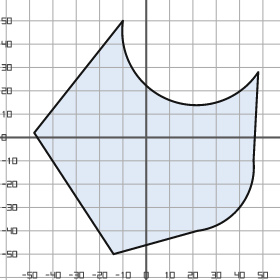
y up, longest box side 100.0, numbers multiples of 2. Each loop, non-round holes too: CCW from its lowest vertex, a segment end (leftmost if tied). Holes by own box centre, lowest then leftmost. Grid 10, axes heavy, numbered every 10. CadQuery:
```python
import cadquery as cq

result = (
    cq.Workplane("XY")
    .moveTo(-14.0, -50.0)
    .lineTo(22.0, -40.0)
    .threePointArc((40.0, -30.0), (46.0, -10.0))
    .lineTo(48.0, 28.0)
    .threePointArc((10.0, 16.0), (-10.0, 50.0))
    .lineTo(-48.0, 2.0)
    .close()
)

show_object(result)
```